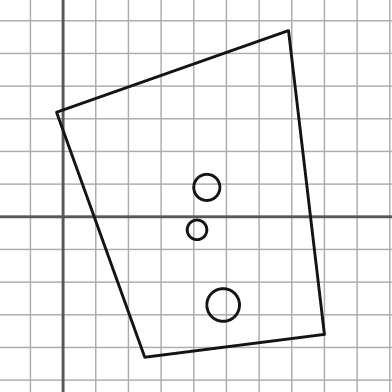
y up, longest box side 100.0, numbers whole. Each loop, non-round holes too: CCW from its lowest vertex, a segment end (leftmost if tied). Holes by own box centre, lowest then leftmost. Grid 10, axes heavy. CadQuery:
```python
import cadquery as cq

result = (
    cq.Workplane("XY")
    .moveTo(25.0, -43.0)
    .lineTo(80.0, -36.0)
    .lineTo(69.0, 57.0)
    .lineTo(-2.0, 32.0)
    .close()
    .moveTo(49.0, -27.0)
    .circle(5.0)
    .moveTo(41.0, -4.0)
    .circle(3.0)
    .moveTo(44.0, 9.0)
    .circle(4.0)
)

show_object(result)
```